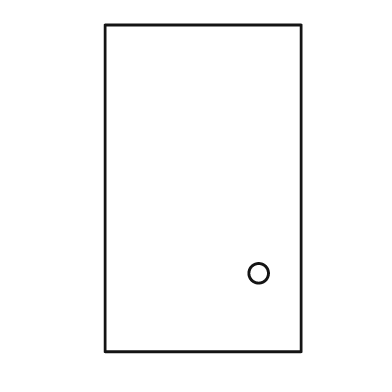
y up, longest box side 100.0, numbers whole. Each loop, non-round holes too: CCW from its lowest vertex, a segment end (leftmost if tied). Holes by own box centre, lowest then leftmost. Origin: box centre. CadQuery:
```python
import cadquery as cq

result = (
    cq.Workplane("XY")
    .moveTo(-30.0, -50.0)
    .lineTo(30.0, -50.0)
    .lineTo(30.0, 50.0)
    .lineTo(-30.0, 50.0)
    .close()
    .moveTo(17.0, -26.0)
    .circle(3.0)
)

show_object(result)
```